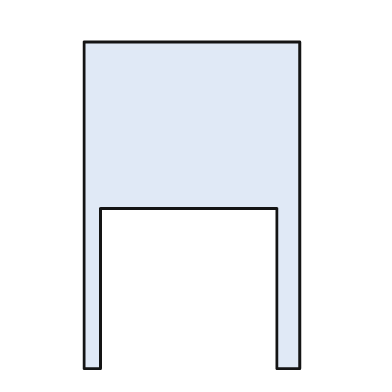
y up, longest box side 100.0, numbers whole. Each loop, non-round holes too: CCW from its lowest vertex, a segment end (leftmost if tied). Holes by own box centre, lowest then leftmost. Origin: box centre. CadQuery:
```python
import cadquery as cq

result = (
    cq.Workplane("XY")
    .moveTo(-33.0, -50.0)
    .lineTo(-28.0, -50.0)
    .lineTo(-28.0, -1.0)
    .lineTo(26.0, -1.0)
    .lineTo(26.0, -50.0)
    .lineTo(33.0, -50.0)
    .lineTo(33.0, 50.0)
    .lineTo(-33.0, 50.0)
    .close()
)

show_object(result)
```